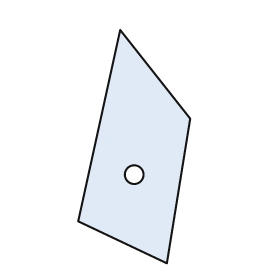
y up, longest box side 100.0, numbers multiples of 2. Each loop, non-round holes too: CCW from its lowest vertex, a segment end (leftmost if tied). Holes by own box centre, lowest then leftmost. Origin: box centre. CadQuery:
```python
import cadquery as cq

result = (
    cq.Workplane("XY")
    .moveTo(14.0, -50.0)
    .lineTo(24.0, 12.0)
    .lineTo(-6.0, 50.0)
    .lineTo(-24.0, -32.0)
    .close()
    .moveTo(0.0, -12.0)
    .circle(4.0)
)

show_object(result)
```